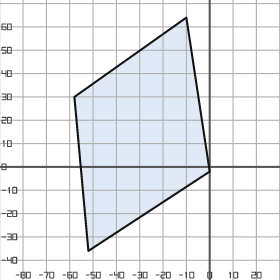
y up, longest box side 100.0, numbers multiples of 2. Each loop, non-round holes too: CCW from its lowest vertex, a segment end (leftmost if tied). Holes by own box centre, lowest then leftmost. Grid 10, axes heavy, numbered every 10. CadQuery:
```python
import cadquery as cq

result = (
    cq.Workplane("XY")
    .moveTo(-52.0, -36.0)
    .lineTo(0.0, -2.0)
    .lineTo(-10.0, 64.0)
    .lineTo(-58.0, 30.0)
    .close()
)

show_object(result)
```